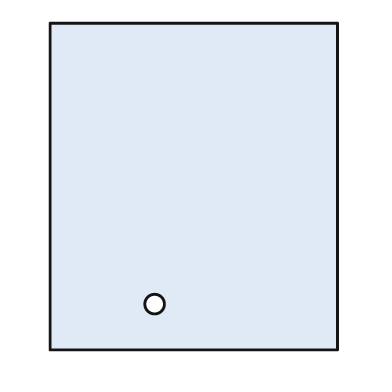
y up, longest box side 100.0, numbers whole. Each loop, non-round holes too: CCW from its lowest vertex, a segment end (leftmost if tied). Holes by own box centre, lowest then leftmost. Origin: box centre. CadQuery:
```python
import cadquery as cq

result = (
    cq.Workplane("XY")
    .moveTo(-44.0, -50.0)
    .lineTo(44.0, -50.0)
    .lineTo(44.0, 50.0)
    .lineTo(-44.0, 50.0)
    .close()
    .moveTo(-12.0, -36.0)
    .circle(3.0)
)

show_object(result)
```